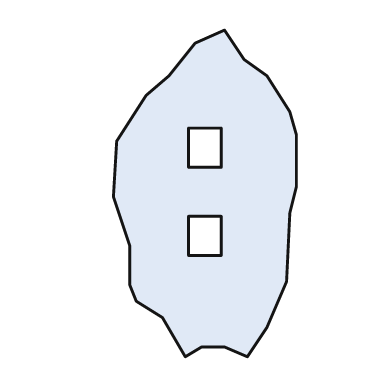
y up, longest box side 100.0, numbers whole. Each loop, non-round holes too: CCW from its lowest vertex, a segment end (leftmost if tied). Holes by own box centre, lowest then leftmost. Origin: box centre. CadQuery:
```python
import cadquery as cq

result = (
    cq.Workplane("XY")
    .moveTo(-6.0, -50.0)
    .lineTo(-1.0, -47.0)
    .lineTo(6.0, -47.0)
    .lineTo(13.0, -50.0)
    .lineTo(19.0, -41.0)
    .lineTo(25.0, -27.0)
    .lineTo(26.0, -6.0)
    .lineTo(28.0, 2.0)
    .lineTo(28.0, 18.0)
    .lineTo(26.0, 25.0)
    .lineTo(19.0, 36.0)
    .lineTo(12.0, 41.0)
    .lineTo(6.0, 50.0)
    .lineTo(-3.0, 46.0)
    .lineTo(-11.0, 36.0)
    .lineTo(-18.0, 30.0)
    .lineTo(-27.0, 16.0)
    .lineTo(-28.0, -1.0)
    .lineTo(-23.0, -16.0)
    .lineTo(-23.0, -28.0)
    .lineTo(-21.0, -33.0)
    .lineTo(-13.0, -38.0)
    .close()
    .moveTo(-5.0, -19.0)
    .lineTo(5.0, -19.0)
    .lineTo(5.0, -7.0)
    .lineTo(-5.0, -7.0)
    .close()
    .moveTo(-5.0, 8.0)
    .lineTo(5.0, 8.0)
    .lineTo(5.0, 20.0)
    .lineTo(-5.0, 20.0)
    .close()
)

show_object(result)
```